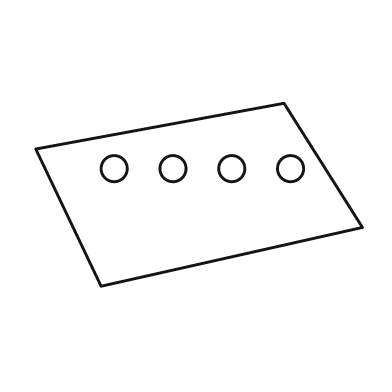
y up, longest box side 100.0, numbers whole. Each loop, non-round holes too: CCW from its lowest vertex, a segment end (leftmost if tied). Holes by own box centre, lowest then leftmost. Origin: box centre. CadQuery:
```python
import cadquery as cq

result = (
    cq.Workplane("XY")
    .moveTo(-30.0, -28.0)
    .lineTo(50.0, -10.0)
    .lineTo(26.0, 28.0)
    .lineTo(-50.0, 14.0)
    .close()
    .moveTo(-26.0, 8.0)
    .circle(4.0)
    .moveTo(-8.0, 8.0)
    .circle(4.0)
    .moveTo(10.0, 8.0)
    .circle(4.0)
    .moveTo(28.0, 8.0)
    .circle(4.0)
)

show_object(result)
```